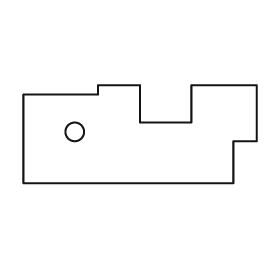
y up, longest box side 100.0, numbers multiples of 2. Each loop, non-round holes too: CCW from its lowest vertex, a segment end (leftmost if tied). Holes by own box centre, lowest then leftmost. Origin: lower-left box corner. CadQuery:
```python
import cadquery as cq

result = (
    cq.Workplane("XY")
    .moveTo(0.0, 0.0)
    .lineTo(90.0, 0.0)
    .lineTo(90.0, 18.0)
    .lineTo(100.0, 18.0)
    .lineTo(100.0, 42.0)
    .lineTo(72.0, 42.0)
    .lineTo(72.0, 26.0)
    .lineTo(50.0, 26.0)
    .lineTo(50.0, 42.0)
    .lineTo(32.0, 42.0)
    .lineTo(32.0, 38.0)
    .lineTo(0.0, 38.0)
    .close()
    .moveTo(22.0, 22.0)
    .circle(4.0)
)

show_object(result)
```